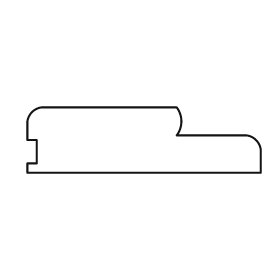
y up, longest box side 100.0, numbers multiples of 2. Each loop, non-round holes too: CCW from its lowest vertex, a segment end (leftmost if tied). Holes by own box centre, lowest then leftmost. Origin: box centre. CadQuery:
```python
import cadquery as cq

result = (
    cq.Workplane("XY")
    .moveTo(-50.0, -14.0)
    .lineTo(50.0, -14.0)
    .lineTo(50.0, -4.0)
    .threePointArc((48.0, 0.0), (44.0, 2.0))
    .lineTo(14.0, 2.0)
    .threePointArc((16.0, 8.0), (14.0, 14.0))
    .lineTo(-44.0, 14.0)
    .threePointArc((-48.0, 12.0), (-50.0, 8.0))
    .lineTo(-50.0, 0.0)
    .lineTo(-46.0, 0.0)
    .lineTo(-46.0, -10.0)
    .lineTo(-50.0, -10.0)
    .close()
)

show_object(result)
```